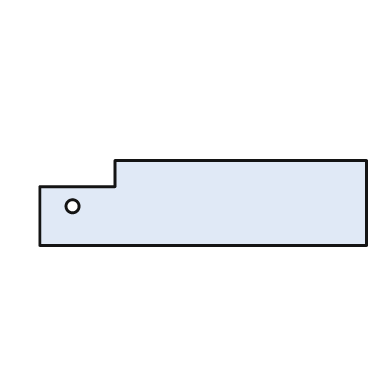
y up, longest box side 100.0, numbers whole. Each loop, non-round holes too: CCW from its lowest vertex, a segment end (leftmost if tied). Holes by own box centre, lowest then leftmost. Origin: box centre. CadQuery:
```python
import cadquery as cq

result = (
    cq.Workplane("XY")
    .moveTo(-50.0, -13.0)
    .lineTo(50.0, -13.0)
    .lineTo(50.0, 13.0)
    .lineTo(-27.0, 13.0)
    .lineTo(-27.0, 5.0)
    .lineTo(-50.0, 5.0)
    .close()
    .moveTo(-40.0, -1.0)
    .circle(2.0)
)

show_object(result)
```